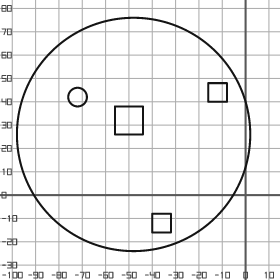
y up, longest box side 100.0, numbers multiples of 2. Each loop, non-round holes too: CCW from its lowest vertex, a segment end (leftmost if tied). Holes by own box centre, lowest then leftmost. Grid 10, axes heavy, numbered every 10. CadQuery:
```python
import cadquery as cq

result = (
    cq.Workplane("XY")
    .moveTo(-48.0, 26.0)
    .circle(50.0)
    .moveTo(-40.0, -16.0)
    .lineTo(-32.0, -16.0)
    .lineTo(-32.0, -8.0)
    .lineTo(-40.0, -8.0)
    .close()
    .moveTo(-56.0, 26.0)
    .lineTo(-44.0, 26.0)
    .lineTo(-44.0, 38.0)
    .lineTo(-56.0, 38.0)
    .close()
    .moveTo(-72.0, 42.0)
    .circle(4.0)
    .moveTo(-16.0, 40.0)
    .lineTo(-8.0, 40.0)
    .lineTo(-8.0, 48.0)
    .lineTo(-16.0, 48.0)
    .close()
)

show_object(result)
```